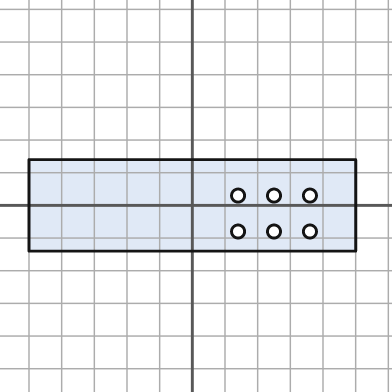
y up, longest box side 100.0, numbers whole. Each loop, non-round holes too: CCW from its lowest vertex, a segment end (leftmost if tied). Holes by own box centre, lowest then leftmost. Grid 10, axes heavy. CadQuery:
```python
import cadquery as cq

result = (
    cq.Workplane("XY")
    .moveTo(-50.0, -14.0)
    .lineTo(50.0, -14.0)
    .lineTo(50.0, 14.0)
    .lineTo(-50.0, 14.0)
    .close()
    .moveTo(14.0, -8.0)
    .circle(2.0)
    .moveTo(25.0, -8.0)
    .circle(2.0)
    .moveTo(36.0, -8.0)
    .circle(2.0)
    .moveTo(14.0, 3.0)
    .circle(2.0)
    .moveTo(25.0, 3.0)
    .circle(2.0)
    .moveTo(36.0, 3.0)
    .circle(2.0)
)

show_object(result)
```